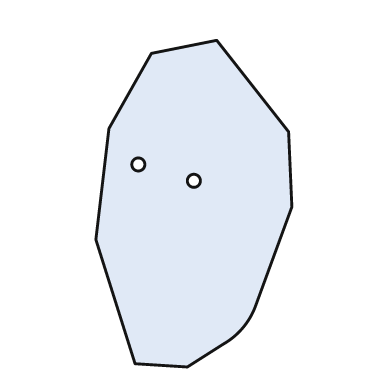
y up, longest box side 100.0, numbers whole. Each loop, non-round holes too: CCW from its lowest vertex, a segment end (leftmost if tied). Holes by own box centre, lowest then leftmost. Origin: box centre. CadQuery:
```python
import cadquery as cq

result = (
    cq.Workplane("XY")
    .moveTo(-2.0, -50.0)
    .lineTo(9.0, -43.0)
    .threePointArc((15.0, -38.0), (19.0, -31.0))
    .lineTo(30.0, -1.0)
    .lineTo(29.0, 22.0)
    .lineTo(7.0, 50.0)
    .lineTo(-13.0, 46.0)
    .lineTo(-26.0, 23.0)
    .lineTo(-30.0, -11.0)
    .lineTo(-18.0, -49.0)
    .close()
    .moveTo(0.0, 7.0)
    .circle(2.0)
    .moveTo(-17.0, 12.0)
    .circle(2.0)
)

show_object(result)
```